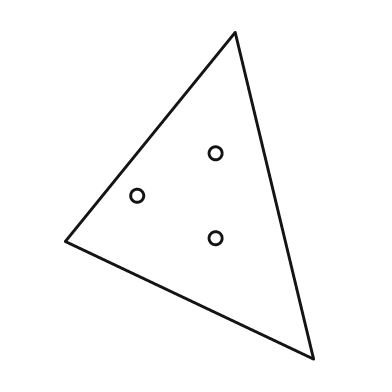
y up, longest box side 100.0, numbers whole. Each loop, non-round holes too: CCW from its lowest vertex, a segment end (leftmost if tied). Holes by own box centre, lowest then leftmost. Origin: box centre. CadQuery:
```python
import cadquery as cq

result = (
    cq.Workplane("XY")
    .moveTo(38.0, -50.0)
    .lineTo(14.0, 50.0)
    .lineTo(-38.0, -14.0)
    .close()
    .moveTo(8.0, -13.0)
    .circle(2.0)
    .moveTo(-16.0, 0.0)
    .circle(2.0)
    .moveTo(8.0, 13.0)
    .circle(2.0)
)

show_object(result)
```